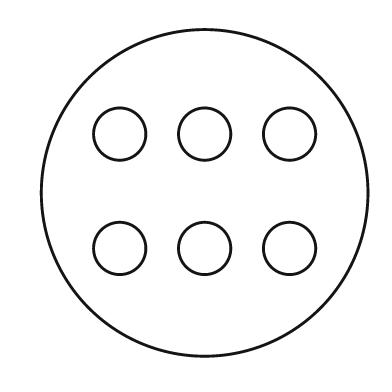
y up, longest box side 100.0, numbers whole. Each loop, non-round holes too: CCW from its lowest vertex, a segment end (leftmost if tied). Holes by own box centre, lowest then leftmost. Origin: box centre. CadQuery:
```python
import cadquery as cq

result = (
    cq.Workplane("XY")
    .moveTo(0.0, 0.0)
    .circle(50.0)
    .moveTo(-26.0, -17.0)
    .circle(8.0)
    .moveTo(0.0, -17.0)
    .circle(8.0)
    .moveTo(26.0, -17.0)
    .circle(8.0)
    .moveTo(-26.0, 18.0)
    .circle(8.0)
    .moveTo(0.0, 18.0)
    .circle(8.0)
    .moveTo(26.0, 18.0)
    .circle(8.0)
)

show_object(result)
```